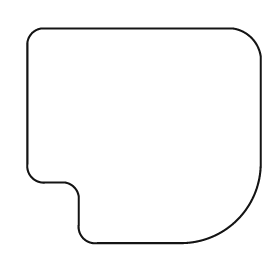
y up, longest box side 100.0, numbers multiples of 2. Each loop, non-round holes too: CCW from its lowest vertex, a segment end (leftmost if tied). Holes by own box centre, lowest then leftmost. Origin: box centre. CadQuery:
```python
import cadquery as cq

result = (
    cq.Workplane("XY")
    .moveTo(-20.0, -46.0)
    .lineTo(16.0, -46.0)
    .threePointArc((40.0, -36.0), (50.0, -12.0))
    .lineTo(50.0, 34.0)
    .threePointArc((46.0, 42.0), (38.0, 46.0))
    .lineTo(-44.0, 46.0)
    .threePointArc((-48.0, 44.0), (-50.0, 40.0))
    .lineTo(-50.0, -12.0)
    .threePointArc((-48.0, -18.0), (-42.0, -20.0))
    .lineTo(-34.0, -20.0)
    .threePointArc((-30.0, -22.0), (-28.0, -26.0))
    .lineTo(-28.0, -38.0)
    .threePointArc((-26.0, -44.0), (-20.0, -46.0))
    .close()
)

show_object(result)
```